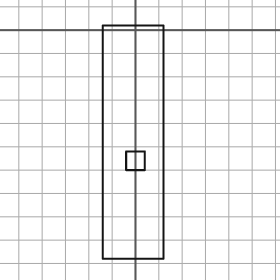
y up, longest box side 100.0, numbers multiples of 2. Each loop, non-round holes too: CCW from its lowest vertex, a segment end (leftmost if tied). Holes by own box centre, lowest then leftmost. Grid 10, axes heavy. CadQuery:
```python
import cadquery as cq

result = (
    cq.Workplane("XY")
    .moveTo(-14.0, -98.0)
    .lineTo(12.0, -98.0)
    .lineTo(12.0, 2.0)
    .lineTo(-14.0, 2.0)
    .close()
    .moveTo(-4.0, -60.0)
    .lineTo(4.0, -60.0)
    .lineTo(4.0, -52.0)
    .lineTo(-4.0, -52.0)
    .close()
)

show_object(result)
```